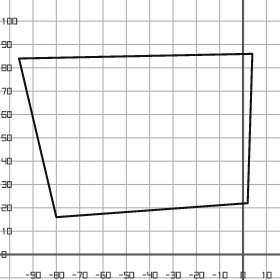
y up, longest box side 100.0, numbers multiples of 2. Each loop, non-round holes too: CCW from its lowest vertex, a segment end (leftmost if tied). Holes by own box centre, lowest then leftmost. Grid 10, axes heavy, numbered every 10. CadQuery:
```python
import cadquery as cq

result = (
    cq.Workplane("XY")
    .moveTo(-80.0, 16.0)
    .lineTo(2.0, 22.0)
    .lineTo(4.0, 86.0)
    .lineTo(-96.0, 84.0)
    .close()
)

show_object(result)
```